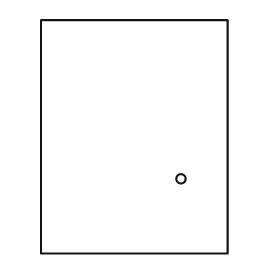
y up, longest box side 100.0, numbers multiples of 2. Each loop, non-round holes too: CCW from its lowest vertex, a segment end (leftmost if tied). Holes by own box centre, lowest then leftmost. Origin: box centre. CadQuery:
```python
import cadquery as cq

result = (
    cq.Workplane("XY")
    .moveTo(-40.0, -50.0)
    .lineTo(40.0, -50.0)
    .lineTo(40.0, 50.0)
    .lineTo(-40.0, 50.0)
    .close()
    .moveTo(20.0, -18.0)
    .circle(2.0)
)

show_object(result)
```